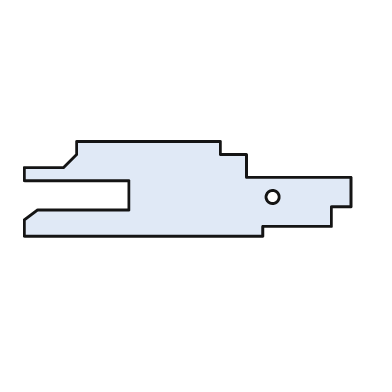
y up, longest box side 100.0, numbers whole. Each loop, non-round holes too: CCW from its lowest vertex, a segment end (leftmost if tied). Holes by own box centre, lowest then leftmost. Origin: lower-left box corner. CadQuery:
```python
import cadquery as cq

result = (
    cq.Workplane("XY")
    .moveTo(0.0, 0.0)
    .lineTo(73.0, 0.0)
    .lineTo(73.0, 3.0)
    .lineTo(94.0, 3.0)
    .lineTo(94.0, 9.0)
    .lineTo(100.0, 9.0)
    .lineTo(100.0, 18.0)
    .lineTo(68.0, 18.0)
    .lineTo(68.0, 25.0)
    .lineTo(60.0, 25.0)
    .lineTo(60.0, 29.0)
    .lineTo(16.0, 29.0)
    .lineTo(16.0, 25.0)
    .lineTo(12.0, 21.0)
    .lineTo(0.0, 21.0)
    .lineTo(0.0, 17.0)
    .lineTo(32.0, 17.0)
    .lineTo(32.0, 8.0)
    .lineTo(4.0, 8.0)
    .lineTo(0.0, 5.0)
    .close()
    .moveTo(76.0, 12.0)
    .circle(2.0)
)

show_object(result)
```